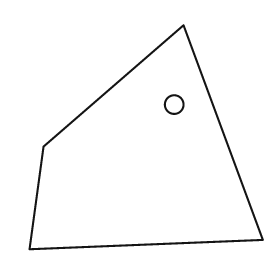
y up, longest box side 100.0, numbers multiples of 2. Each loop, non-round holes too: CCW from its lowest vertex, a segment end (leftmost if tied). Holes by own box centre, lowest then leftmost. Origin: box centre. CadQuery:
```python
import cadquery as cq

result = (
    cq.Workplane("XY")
    .moveTo(-50.0, -48.0)
    .lineTo(50.0, -44.0)
    .lineTo(16.0, 48.0)
    .lineTo(-44.0, -4.0)
    .close()
    .moveTo(12.0, 14.0)
    .circle(4.0)
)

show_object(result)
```